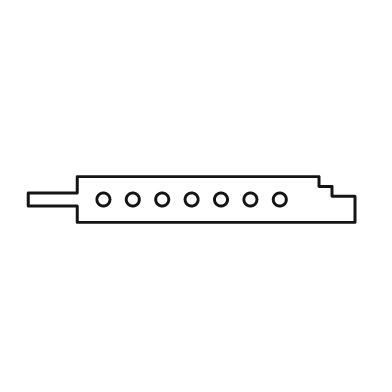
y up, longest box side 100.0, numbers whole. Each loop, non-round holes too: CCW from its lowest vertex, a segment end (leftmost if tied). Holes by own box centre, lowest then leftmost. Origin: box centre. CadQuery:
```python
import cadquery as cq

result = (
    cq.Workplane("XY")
    .moveTo(-35.0, -7.0)
    .lineTo(50.0, -7.0)
    .lineTo(50.0, 1.0)
    .lineTo(43.0, 1.0)
    .lineTo(43.0, 4.0)
    .lineTo(39.0, 4.0)
    .lineTo(39.0, 7.0)
    .lineTo(-35.0, 7.0)
    .lineTo(-35.0, 2.0)
    .lineTo(-50.0, 2.0)
    .lineTo(-50.0, -2.0)
    .lineTo(-35.0, -2.0)
    .close()
    .moveTo(-27.0, 0.0)
    .circle(2.0)
    .moveTo(-18.0, 0.0)
    .circle(2.0)
    .moveTo(-9.0, 0.0)
    .circle(2.0)
    .moveTo(0.0, 0.0)
    .circle(2.0)
    .moveTo(9.0, 0.0)
    .circle(2.0)
    .moveTo(18.0, 0.0)
    .circle(2.0)
    .moveTo(27.0, 0.0)
    .circle(2.0)
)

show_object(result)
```